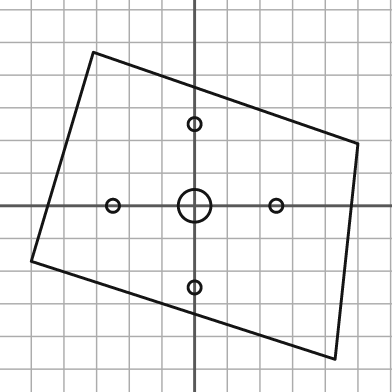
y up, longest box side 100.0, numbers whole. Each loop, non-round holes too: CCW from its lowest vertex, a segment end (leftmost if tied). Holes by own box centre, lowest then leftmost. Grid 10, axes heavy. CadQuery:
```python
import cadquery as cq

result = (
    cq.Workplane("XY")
    .moveTo(43.0, -47.0)
    .lineTo(50.0, 19.0)
    .lineTo(-31.0, 47.0)
    .lineTo(-50.0, -17.0)
    .close()
    .moveTo(0.0, -25.0)
    .circle(2.0)
    .moveTo(-25.0, 0.0)
    .circle(2.0)
    .moveTo(0.0, 0.0)
    .circle(5.0)
    .moveTo(25.0, 0.0)
    .circle(2.0)
    .moveTo(0.0, 25.0)
    .circle(2.0)
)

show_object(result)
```